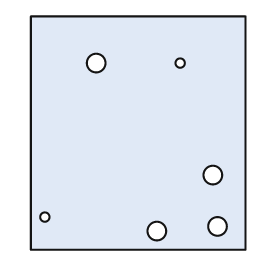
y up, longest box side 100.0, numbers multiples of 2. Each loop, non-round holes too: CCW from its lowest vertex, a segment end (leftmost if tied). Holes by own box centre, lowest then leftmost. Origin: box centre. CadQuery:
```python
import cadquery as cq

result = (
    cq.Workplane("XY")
    .moveTo(-46.0, -50.0)
    .lineTo(46.0, -50.0)
    .lineTo(46.0, 50.0)
    .lineTo(-46.0, 50.0)
    .close()
    .moveTo(8.0, -42.0)
    .circle(4.0)
    .moveTo(34.0, -40.0)
    .circle(4.0)
    .moveTo(-40.0, -36.0)
    .circle(2.0)
    .moveTo(32.0, -18.0)
    .circle(4.0)
    .moveTo(-18.0, 30.0)
    .circle(4.0)
    .moveTo(18.0, 30.0)
    .circle(2.0)
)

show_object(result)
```